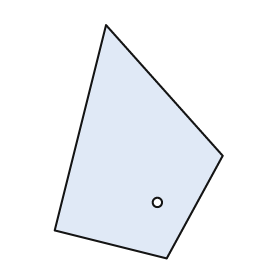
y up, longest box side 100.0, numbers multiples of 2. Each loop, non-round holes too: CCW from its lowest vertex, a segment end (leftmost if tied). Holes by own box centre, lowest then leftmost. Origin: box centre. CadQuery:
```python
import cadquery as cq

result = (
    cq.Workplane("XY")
    .moveTo(12.0, -50.0)
    .lineTo(36.0, -6.0)
    .lineTo(-14.0, 50.0)
    .lineTo(-36.0, -38.0)
    .close()
    .moveTo(8.0, -26.0)
    .circle(2.0)
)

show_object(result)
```